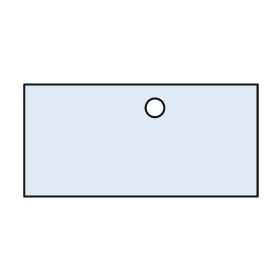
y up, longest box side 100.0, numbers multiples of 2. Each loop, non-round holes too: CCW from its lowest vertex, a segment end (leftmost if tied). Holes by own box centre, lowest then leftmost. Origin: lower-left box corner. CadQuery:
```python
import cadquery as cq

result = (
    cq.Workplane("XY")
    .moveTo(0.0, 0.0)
    .lineTo(100.0, 0.0)
    .lineTo(100.0, 48.0)
    .lineTo(0.0, 48.0)
    .close()
    .moveTo(56.0, 38.0)
    .circle(4.0)
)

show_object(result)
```